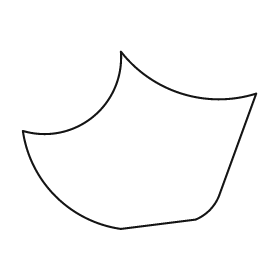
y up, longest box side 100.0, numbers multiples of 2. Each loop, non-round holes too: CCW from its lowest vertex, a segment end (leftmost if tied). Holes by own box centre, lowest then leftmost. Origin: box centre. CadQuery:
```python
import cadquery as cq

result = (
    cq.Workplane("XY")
    .moveTo(-8.0, -38.0)
    .lineTo(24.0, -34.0)
    .threePointArc((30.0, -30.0), (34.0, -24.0))
    .lineTo(50.0, 20.0)
    .threePointArc((18.0, 20.0), (-8.0, 38.0))
    .threePointArc((-20.0, 10.0), (-50.0, 4.0))
    .threePointArc((-36.0, -24.0), (-8.0, -38.0))
    .close()
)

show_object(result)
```